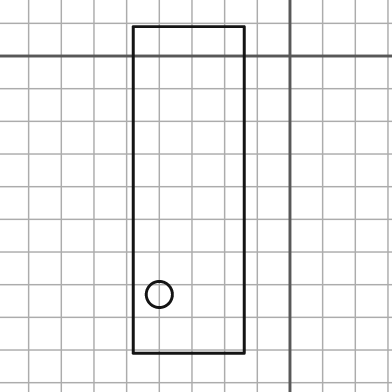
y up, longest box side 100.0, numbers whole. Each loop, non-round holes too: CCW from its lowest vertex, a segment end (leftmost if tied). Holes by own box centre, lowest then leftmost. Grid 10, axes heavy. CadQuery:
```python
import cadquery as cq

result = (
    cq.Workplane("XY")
    .moveTo(-48.0, -91.0)
    .lineTo(-14.0, -91.0)
    .lineTo(-14.0, 9.0)
    .lineTo(-48.0, 9.0)
    .close()
    .moveTo(-40.0, -73.0)
    .circle(4.0)
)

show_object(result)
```